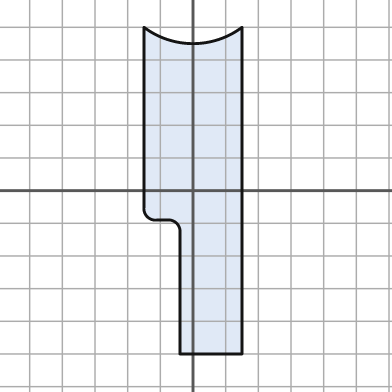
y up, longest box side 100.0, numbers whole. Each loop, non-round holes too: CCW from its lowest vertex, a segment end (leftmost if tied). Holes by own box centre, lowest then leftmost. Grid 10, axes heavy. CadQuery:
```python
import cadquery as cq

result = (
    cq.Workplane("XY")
    .moveTo(-4.0, -50.0)
    .lineTo(15.0, -50.0)
    .lineTo(15.0, 50.0)
    .threePointArc((0.0, 45.0), (-15.0, 50.0))
    .lineTo(-15.0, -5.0)
    .threePointArc((-14.0, -8.0), (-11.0, -9.0))
    .lineTo(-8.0, -9.0)
    .threePointArc((-5.0, -10.0), (-4.0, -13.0))
    .close()
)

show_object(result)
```